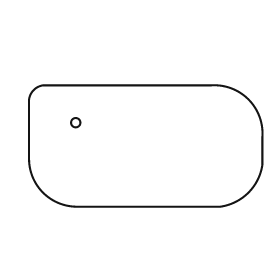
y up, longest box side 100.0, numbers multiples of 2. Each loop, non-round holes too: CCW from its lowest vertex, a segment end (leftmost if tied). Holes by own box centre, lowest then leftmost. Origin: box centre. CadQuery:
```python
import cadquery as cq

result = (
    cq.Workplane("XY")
    .moveTo(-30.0, -26.0)
    .lineTo(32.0, -26.0)
    .threePointArc((44.0, -20.0), (50.0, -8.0))
    .lineTo(50.0, 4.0)
    .threePointArc((44.0, 20.0), (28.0, 26.0))
    .lineTo(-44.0, 26.0)
    .threePointArc((-48.0, 24.0), (-50.0, 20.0))
    .lineTo(-50.0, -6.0)
    .threePointArc((-44.0, -20.0), (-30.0, -26.0))
    .close()
    .moveTo(-30.0, 10.0)
    .circle(2.0)
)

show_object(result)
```